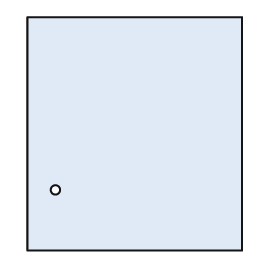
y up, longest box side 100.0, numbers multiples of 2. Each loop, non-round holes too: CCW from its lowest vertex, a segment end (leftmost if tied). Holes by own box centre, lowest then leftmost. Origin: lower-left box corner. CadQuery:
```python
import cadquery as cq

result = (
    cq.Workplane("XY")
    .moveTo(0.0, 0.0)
    .lineTo(92.0, 0.0)
    .lineTo(92.0, 100.0)
    .lineTo(0.0, 100.0)
    .close()
    .moveTo(12.0, 26.0)
    .circle(2.0)
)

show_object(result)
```